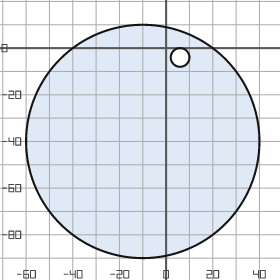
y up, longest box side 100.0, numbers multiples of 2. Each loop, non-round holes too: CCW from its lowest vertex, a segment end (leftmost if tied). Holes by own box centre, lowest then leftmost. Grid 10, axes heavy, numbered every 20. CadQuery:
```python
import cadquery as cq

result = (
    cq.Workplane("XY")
    .moveTo(-10.0, -40.0)
    .circle(50.0)
    .moveTo(6.0, -4.0)
    .circle(4.0)
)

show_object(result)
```